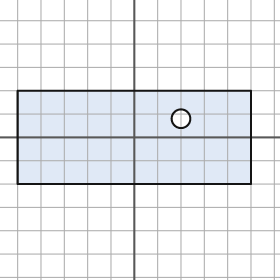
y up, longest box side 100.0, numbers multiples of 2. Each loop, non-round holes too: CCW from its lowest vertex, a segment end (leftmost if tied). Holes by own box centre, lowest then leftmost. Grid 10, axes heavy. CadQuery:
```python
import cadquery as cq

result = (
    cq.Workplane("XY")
    .moveTo(-50.0, -20.0)
    .lineTo(50.0, -20.0)
    .lineTo(50.0, 20.0)
    .lineTo(-50.0, 20.0)
    .close()
    .moveTo(20.0, 8.0)
    .circle(4.0)
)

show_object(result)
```